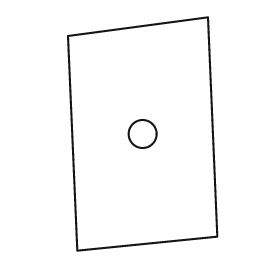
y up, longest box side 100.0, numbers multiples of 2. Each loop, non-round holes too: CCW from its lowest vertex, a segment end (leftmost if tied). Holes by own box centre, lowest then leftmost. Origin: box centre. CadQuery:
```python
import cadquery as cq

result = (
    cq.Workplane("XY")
    .moveTo(-28.0, -50.0)
    .lineTo(32.0, -44.0)
    .lineTo(28.0, 50.0)
    .lineTo(-32.0, 42.0)
    .close()
    .moveTo(0.0, 0.0)
    .circle(6.0)
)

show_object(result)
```